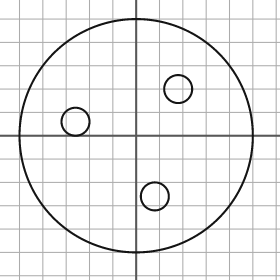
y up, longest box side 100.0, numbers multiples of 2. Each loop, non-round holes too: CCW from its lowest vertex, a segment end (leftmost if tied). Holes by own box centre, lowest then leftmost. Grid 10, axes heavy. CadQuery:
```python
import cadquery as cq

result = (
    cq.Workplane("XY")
    .moveTo(0.0, 0.0)
    .circle(50.0)
    .moveTo(8.0, -26.0)
    .circle(6.0)
    .moveTo(-26.0, 6.0)
    .circle(6.0)
    .moveTo(18.0, 20.0)
    .circle(6.0)
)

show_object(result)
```